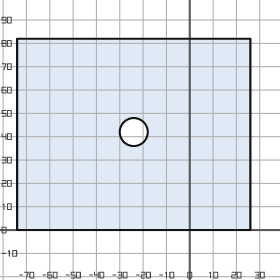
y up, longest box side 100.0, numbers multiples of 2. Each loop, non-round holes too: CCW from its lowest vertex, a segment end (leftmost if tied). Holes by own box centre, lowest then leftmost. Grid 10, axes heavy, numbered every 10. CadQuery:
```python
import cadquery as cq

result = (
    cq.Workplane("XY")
    .moveTo(-74.0, 0.0)
    .lineTo(26.0, 0.0)
    .lineTo(26.0, 82.0)
    .lineTo(-74.0, 82.0)
    .close()
    .moveTo(-24.0, 42.0)
    .circle(6.0)
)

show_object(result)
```